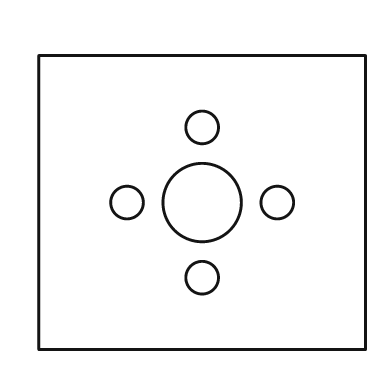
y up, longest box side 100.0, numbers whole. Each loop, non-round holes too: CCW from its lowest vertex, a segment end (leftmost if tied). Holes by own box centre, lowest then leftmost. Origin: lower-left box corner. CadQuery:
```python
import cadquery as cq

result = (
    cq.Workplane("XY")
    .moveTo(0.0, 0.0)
    .lineTo(100.0, 0.0)
    .lineTo(100.0, 90.0)
    .lineTo(0.0, 90.0)
    .close()
    .moveTo(50.0, 22.0)
    .circle(5.0)
    .moveTo(27.0, 45.0)
    .circle(5.0)
    .moveTo(50.0, 45.0)
    .circle(12.0)
    .moveTo(73.0, 45.0)
    .circle(5.0)
    .moveTo(50.0, 68.0)
    .circle(5.0)
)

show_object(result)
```